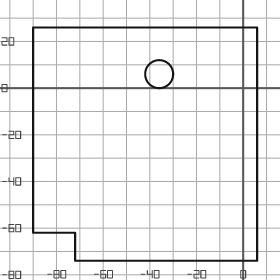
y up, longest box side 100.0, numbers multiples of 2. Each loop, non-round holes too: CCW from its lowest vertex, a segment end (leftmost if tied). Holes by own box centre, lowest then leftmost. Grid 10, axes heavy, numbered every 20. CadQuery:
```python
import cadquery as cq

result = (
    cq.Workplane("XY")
    .moveTo(-72.0, -74.0)
    .lineTo(6.0, -74.0)
    .lineTo(6.0, 26.0)
    .lineTo(-90.0, 26.0)
    .lineTo(-90.0, -62.0)
    .lineTo(-72.0, -62.0)
    .close()
    .moveTo(-36.0, 6.0)
    .circle(6.0)
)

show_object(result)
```